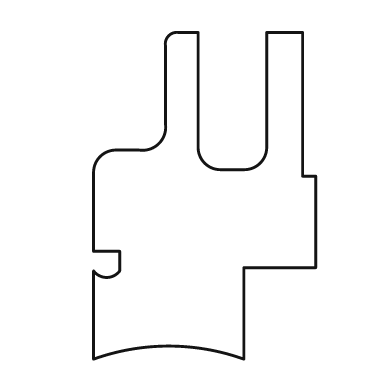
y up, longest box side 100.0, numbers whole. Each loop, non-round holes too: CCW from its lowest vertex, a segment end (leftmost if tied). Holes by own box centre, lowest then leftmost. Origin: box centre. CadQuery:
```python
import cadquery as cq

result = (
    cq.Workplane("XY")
    .moveTo(-34.0, -50.0)
    .threePointArc((-11.0, -46.0), (12.0, -50.0))
    .lineTo(12.0, -22.0)
    .lineTo(34.0, -22.0)
    .lineTo(34.0, 6.0)
    .lineTo(30.0, 6.0)
    .lineTo(30.0, 50.0)
    .lineTo(19.0, 50.0)
    .lineTo(19.0, 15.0)
    .threePointArc((17.0, 10.0), (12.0, 8.0))
    .lineTo(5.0, 8.0)
    .threePointArc((0.0, 10.0), (-2.0, 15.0))
    .lineTo(-2.0, 50.0)
    .lineTo(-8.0, 50.0)
    .threePointArc((-11.0, 49.0), (-12.0, 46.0))
    .lineTo(-12.0, 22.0)
    .threePointArc((-14.0, 16.0), (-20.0, 14.0))
    .lineTo(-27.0, 14.0)
    .threePointArc((-32.0, 12.0), (-34.0, 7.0))
    .lineTo(-34.0, -17.0)
    .lineTo(-26.0, -17.0)
    .lineTo(-26.0, -23.0)
    .threePointArc((-30.0, -25.0), (-34.0, -23.0))
    .close()
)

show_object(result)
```